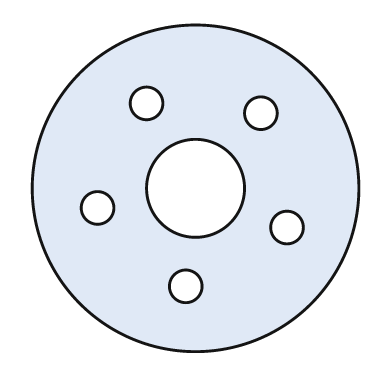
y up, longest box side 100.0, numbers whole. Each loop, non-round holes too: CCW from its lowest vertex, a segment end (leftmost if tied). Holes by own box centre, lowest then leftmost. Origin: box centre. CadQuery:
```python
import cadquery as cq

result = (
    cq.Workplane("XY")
    .moveTo(0.0, 0.0)
    .circle(50.0)
    .moveTo(-3.0, -30.0)
    .circle(5.0)
    .moveTo(28.0, -12.0)
    .circle(5.0)
    .moveTo(-30.0, -6.0)
    .circle(5.0)
    .moveTo(0.0, 0.0)
    .circle(15.0)
    .moveTo(20.0, 23.0)
    .circle(5.0)
    .moveTo(-15.0, 26.0)
    .circle(5.0)
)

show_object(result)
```